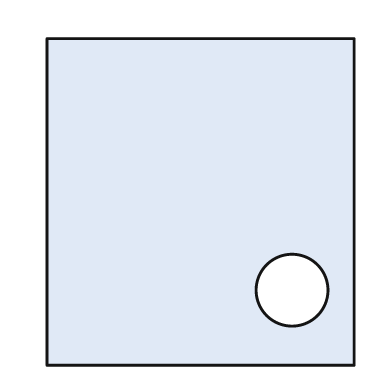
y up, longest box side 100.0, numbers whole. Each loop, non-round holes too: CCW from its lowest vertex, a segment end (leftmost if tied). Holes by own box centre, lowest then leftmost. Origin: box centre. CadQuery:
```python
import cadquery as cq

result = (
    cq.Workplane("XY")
    .moveTo(-47.0, -50.0)
    .lineTo(47.0, -50.0)
    .lineTo(47.0, 50.0)
    .lineTo(-47.0, 50.0)
    .close()
    .moveTo(28.0, -27.0)
    .circle(11.0)
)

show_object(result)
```